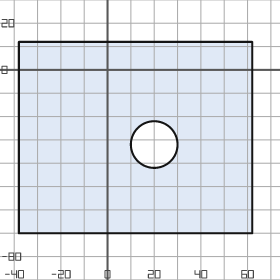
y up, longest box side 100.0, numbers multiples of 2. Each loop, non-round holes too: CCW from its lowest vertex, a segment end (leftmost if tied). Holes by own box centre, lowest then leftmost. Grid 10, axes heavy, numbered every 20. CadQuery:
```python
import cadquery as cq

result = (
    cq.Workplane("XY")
    .moveTo(-38.0, -70.0)
    .lineTo(62.0, -70.0)
    .lineTo(62.0, 12.0)
    .lineTo(-38.0, 12.0)
    .close()
    .moveTo(20.0, -32.0)
    .circle(10.0)
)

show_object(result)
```